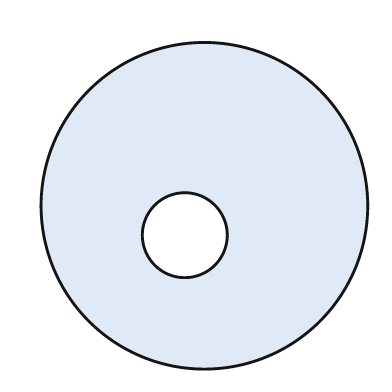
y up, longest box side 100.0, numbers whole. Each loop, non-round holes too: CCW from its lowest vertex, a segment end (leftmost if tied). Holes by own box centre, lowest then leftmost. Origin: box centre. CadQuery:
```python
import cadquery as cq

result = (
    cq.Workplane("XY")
    .moveTo(0.0, 0.0)
    .circle(50.0)
    .moveTo(-6.0, -9.0)
    .circle(13.0)
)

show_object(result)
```